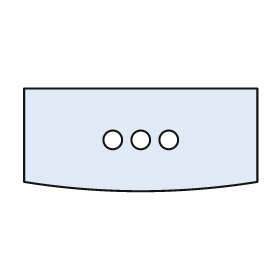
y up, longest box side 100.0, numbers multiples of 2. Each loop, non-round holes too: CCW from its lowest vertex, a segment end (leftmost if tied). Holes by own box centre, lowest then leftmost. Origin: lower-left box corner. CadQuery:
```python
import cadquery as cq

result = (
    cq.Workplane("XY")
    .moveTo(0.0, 4.0)
    .threePointArc((50.0, 0.0), (100.0, 4.0))
    .lineTo(100.0, 44.0)
    .lineTo(0.0, 44.0)
    .close()
    .moveTo(38.0, 22.0)
    .circle(4.0)
    .moveTo(50.0, 22.0)
    .circle(4.0)
    .moveTo(62.0, 22.0)
    .circle(4.0)
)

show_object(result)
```